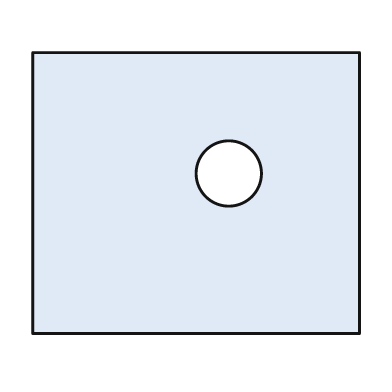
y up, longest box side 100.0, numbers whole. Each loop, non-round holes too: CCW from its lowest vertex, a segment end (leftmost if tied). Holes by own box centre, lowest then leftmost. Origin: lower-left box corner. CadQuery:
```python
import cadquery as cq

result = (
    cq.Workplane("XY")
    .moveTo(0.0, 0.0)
    .lineTo(100.0, 0.0)
    .lineTo(100.0, 86.0)
    .lineTo(0.0, 86.0)
    .close()
    .moveTo(60.0, 49.0)
    .circle(10.0)
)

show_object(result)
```